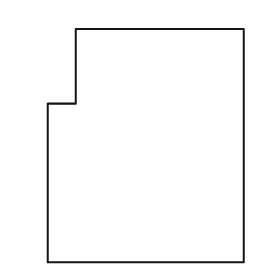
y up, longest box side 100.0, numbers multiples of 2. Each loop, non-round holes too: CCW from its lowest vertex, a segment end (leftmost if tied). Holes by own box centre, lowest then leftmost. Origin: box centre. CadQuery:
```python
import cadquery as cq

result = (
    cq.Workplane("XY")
    .moveTo(-42.0, -50.0)
    .lineTo(42.0, -50.0)
    .lineTo(42.0, 50.0)
    .lineTo(-30.0, 50.0)
    .lineTo(-30.0, 18.0)
    .lineTo(-42.0, 18.0)
    .close()
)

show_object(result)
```